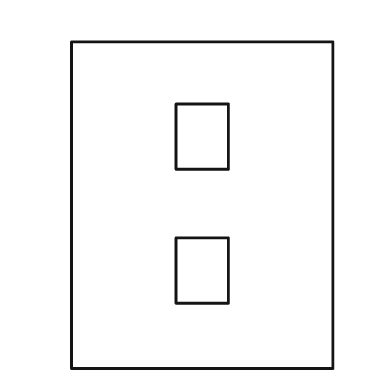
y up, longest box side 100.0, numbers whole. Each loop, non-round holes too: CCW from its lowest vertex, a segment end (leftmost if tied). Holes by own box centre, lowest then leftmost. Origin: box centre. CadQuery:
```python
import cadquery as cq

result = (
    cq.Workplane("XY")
    .moveTo(-40.0, -50.0)
    .lineTo(40.0, -50.0)
    .lineTo(40.0, 50.0)
    .lineTo(-40.0, 50.0)
    .close()
    .moveTo(-8.0, -30.0)
    .lineTo(8.0, -30.0)
    .lineTo(8.0, -10.0)
    .lineTo(-8.0, -10.0)
    .close()
    .moveTo(-8.0, 11.0)
    .lineTo(8.0, 11.0)
    .lineTo(8.0, 31.0)
    .lineTo(-8.0, 31.0)
    .close()
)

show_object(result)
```